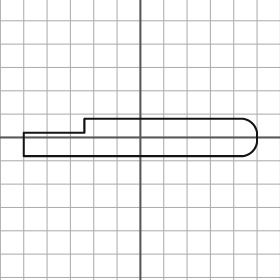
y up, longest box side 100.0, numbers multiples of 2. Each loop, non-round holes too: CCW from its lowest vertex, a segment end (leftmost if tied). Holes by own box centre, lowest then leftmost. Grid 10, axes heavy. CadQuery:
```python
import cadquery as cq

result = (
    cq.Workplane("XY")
    .moveTo(-50.0, -8.0)
    .lineTo(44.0, -8.0)
    .threePointArc((48.0, -6.0), (50.0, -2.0))
    .lineTo(50.0, 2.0)
    .threePointArc((48.0, 6.0), (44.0, 8.0))
    .lineTo(-24.0, 8.0)
    .lineTo(-24.0, 2.0)
    .lineTo(-50.0, 2.0)
    .close()
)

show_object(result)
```